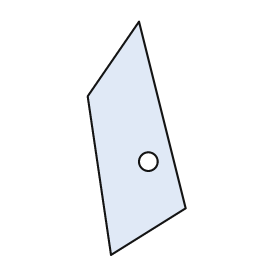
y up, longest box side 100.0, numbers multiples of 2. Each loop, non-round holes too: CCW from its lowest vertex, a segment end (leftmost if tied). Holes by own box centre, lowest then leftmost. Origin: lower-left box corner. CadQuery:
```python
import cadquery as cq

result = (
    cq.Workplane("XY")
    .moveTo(10.0, 0.0)
    .lineTo(42.0, 20.0)
    .lineTo(22.0, 100.0)
    .lineTo(0.0, 68.0)
    .close()
    .moveTo(26.0, 40.0)
    .circle(4.0)
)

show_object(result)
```